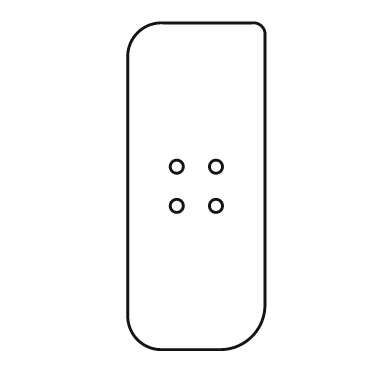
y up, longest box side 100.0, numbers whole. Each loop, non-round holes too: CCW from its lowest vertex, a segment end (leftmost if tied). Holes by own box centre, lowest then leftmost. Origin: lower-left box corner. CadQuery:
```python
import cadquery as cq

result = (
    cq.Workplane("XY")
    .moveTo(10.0, 0.0)
    .lineTo(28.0, 0.0)
    .threePointArc((38.0, 4.0), (42.0, 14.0))
    .lineTo(42.0, 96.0)
    .threePointArc((41.0, 99.0), (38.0, 100.0))
    .lineTo(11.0, 100.0)
    .threePointArc((3.0, 97.0), (0.0, 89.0))
    .lineTo(0.0, 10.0)
    .threePointArc((3.0, 3.0), (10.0, 0.0))
    .close()
    .moveTo(15.0, 44.0)
    .circle(2.0)
    .moveTo(27.0, 44.0)
    .circle(2.0)
    .moveTo(15.0, 56.0)
    .circle(2.0)
    .moveTo(27.0, 56.0)
    .circle(2.0)
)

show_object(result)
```